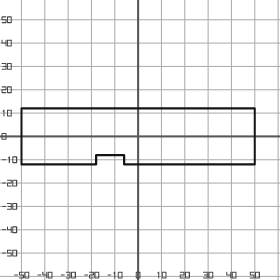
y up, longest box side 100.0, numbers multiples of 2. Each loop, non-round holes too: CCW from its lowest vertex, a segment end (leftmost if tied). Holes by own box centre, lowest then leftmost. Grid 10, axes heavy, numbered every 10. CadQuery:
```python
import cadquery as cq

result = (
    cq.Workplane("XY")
    .moveTo(-50.0, -12.0)
    .lineTo(-18.0, -12.0)
    .lineTo(-18.0, -8.0)
    .lineTo(-6.0, -8.0)
    .lineTo(-6.0, -12.0)
    .lineTo(50.0, -12.0)
    .lineTo(50.0, 12.0)
    .lineTo(-50.0, 12.0)
    .close()
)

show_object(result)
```